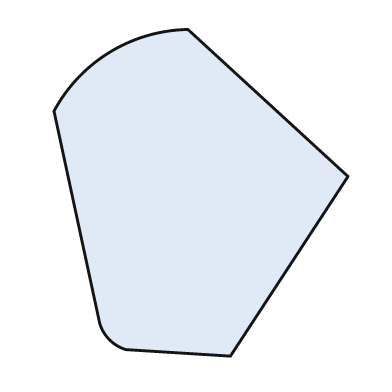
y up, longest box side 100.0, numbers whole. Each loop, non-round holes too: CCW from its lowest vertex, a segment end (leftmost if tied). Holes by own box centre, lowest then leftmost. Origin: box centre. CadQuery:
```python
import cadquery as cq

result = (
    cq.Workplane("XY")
    .moveTo(9.0, -50.0)
    .lineTo(45.0, 5.0)
    .lineTo(-4.0, 50.0)
    .threePointArc((-28.0, 43.0), (-45.0, 25.0))
    .lineTo(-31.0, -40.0)
    .threePointArc((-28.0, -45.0), (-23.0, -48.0))
    .close()
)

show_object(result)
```